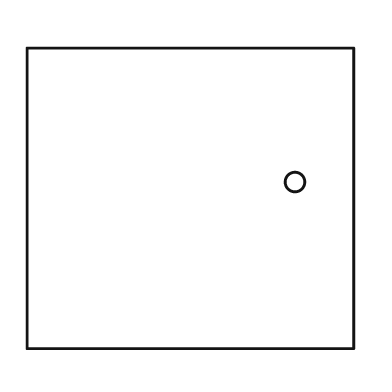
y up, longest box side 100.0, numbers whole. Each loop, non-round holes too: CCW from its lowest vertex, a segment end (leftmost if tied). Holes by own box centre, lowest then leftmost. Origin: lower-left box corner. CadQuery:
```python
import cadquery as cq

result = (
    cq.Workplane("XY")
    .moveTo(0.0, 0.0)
    .lineTo(100.0, 0.0)
    .lineTo(100.0, 92.0)
    .lineTo(0.0, 92.0)
    .close()
    .moveTo(82.0, 51.0)
    .circle(3.0)
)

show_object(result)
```